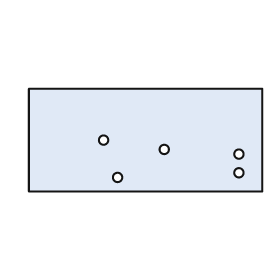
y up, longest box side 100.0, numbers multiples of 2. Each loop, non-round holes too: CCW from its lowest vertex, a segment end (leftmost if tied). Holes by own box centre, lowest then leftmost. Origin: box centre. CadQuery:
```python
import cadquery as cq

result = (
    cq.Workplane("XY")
    .moveTo(-50.0, -22.0)
    .lineTo(50.0, -22.0)
    .lineTo(50.0, 22.0)
    .lineTo(-50.0, 22.0)
    .close()
    .moveTo(-12.0, -16.0)
    .circle(2.0)
    .moveTo(40.0, -14.0)
    .circle(2.0)
    .moveTo(40.0, -6.0)
    .circle(2.0)
    .moveTo(8.0, -4.0)
    .circle(2.0)
    .moveTo(-18.0, 0.0)
    .circle(2.0)
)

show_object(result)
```